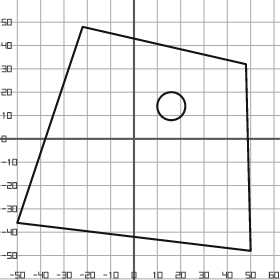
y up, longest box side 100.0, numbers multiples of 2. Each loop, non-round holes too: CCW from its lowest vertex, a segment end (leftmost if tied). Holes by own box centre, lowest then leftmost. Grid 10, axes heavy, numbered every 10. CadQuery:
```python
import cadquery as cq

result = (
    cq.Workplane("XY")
    .moveTo(50.0, -48.0)
    .lineTo(48.0, 32.0)
    .lineTo(-22.0, 48.0)
    .lineTo(-50.0, -36.0)
    .close()
    .moveTo(16.0, 14.0)
    .circle(6.0)
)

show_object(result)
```